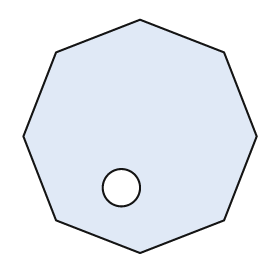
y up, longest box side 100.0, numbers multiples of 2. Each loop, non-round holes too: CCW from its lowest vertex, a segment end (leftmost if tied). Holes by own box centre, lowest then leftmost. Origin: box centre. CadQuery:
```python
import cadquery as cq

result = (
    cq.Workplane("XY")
    .moveTo(0.0, -50.0)
    .lineTo(36.0, -36.0)
    .lineTo(50.0, 0.0)
    .lineTo(36.0, 36.0)
    .lineTo(0.0, 50.0)
    .lineTo(-36.0, 36.0)
    .lineTo(-50.0, 0.0)
    .lineTo(-36.0, -36.0)
    .close()
    .moveTo(-8.0, -22.0)
    .circle(8.0)
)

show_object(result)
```